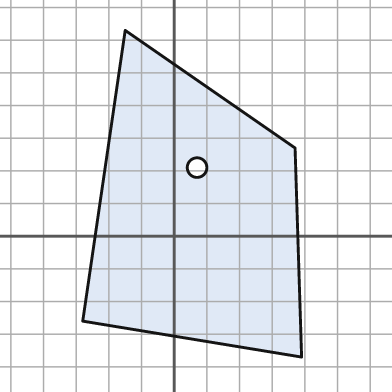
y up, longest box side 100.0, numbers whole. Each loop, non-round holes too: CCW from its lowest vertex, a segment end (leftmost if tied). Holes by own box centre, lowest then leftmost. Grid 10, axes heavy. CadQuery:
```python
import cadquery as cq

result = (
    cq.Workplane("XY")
    .moveTo(39.0, -37.0)
    .lineTo(37.0, 27.0)
    .lineTo(-15.0, 63.0)
    .lineTo(-28.0, -26.0)
    .close()
    .moveTo(7.0, 21.0)
    .circle(3.0)
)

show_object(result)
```